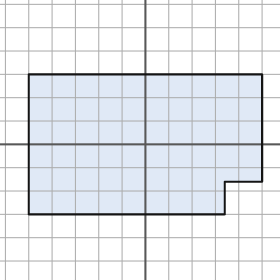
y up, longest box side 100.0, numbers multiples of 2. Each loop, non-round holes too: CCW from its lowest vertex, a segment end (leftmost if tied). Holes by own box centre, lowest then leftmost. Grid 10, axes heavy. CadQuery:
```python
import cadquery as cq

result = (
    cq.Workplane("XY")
    .moveTo(-50.0, -30.0)
    .lineTo(34.0, -30.0)
    .lineTo(34.0, -16.0)
    .lineTo(50.0, -16.0)
    .lineTo(50.0, 30.0)
    .lineTo(-50.0, 30.0)
    .close()
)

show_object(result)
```